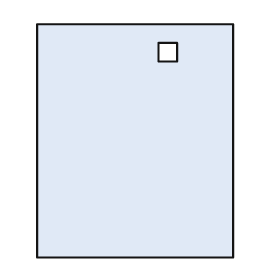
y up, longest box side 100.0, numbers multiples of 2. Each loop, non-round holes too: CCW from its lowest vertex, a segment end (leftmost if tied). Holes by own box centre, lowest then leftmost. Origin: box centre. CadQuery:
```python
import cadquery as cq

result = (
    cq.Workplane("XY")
    .moveTo(-42.0, -50.0)
    .lineTo(42.0, -50.0)
    .lineTo(42.0, 50.0)
    .lineTo(-42.0, 50.0)
    .close()
    .moveTo(10.0, 34.0)
    .lineTo(18.0, 34.0)
    .lineTo(18.0, 42.0)
    .lineTo(10.0, 42.0)
    .close()
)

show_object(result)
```